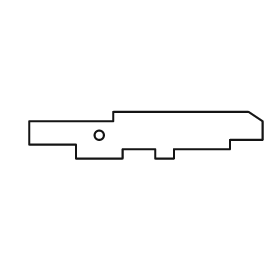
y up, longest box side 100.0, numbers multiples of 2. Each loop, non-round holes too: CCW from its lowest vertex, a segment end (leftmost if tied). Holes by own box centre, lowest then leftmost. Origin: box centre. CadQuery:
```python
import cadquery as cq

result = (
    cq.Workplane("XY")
    .moveTo(-30.0, -10.0)
    .lineTo(-10.0, -10.0)
    .lineTo(-10.0, -6.0)
    .lineTo(4.0, -6.0)
    .lineTo(4.0, -10.0)
    .lineTo(12.0, -10.0)
    .lineTo(12.0, -6.0)
    .lineTo(36.0, -6.0)
    .lineTo(36.0, -2.0)
    .lineTo(50.0, -2.0)
    .lineTo(50.0, 6.0)
    .lineTo(44.0, 10.0)
    .lineTo(-14.0, 10.0)
    .lineTo(-14.0, 6.0)
    .lineTo(-50.0, 6.0)
    .lineTo(-50.0, -4.0)
    .lineTo(-30.0, -4.0)
    .close()
    .moveTo(-20.0, 0.0)
    .circle(2.0)
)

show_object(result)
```